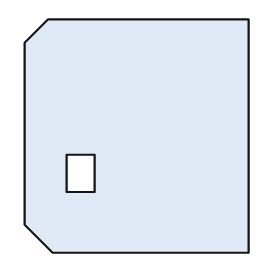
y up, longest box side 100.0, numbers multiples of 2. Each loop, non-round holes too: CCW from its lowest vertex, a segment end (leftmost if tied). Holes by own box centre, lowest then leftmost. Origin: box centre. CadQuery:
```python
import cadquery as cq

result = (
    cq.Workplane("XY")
    .moveTo(-36.0, -50.0)
    .lineTo(48.0, -50.0)
    .lineTo(48.0, 50.0)
    .lineTo(-38.0, 50.0)
    .lineTo(-48.0, 40.0)
    .lineTo(-48.0, -38.0)
    .close()
    .moveTo(-30.0, -24.0)
    .lineTo(-18.0, -24.0)
    .lineTo(-18.0, -8.0)
    .lineTo(-30.0, -8.0)
    .close()
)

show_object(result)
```